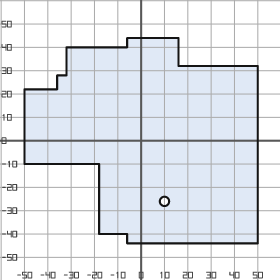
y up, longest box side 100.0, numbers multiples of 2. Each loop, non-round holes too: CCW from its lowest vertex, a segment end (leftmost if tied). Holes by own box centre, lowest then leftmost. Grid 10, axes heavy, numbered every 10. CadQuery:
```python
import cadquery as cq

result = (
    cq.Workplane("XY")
    .moveTo(-6.0, -44.0)
    .lineTo(50.0, -44.0)
    .lineTo(50.0, 32.0)
    .lineTo(16.0, 32.0)
    .lineTo(16.0, 44.0)
    .lineTo(-6.0, 44.0)
    .lineTo(-6.0, 40.0)
    .lineTo(-32.0, 40.0)
    .lineTo(-32.0, 28.0)
    .lineTo(-36.0, 28.0)
    .lineTo(-36.0, 22.0)
    .lineTo(-50.0, 22.0)
    .lineTo(-50.0, -10.0)
    .lineTo(-18.0, -10.0)
    .lineTo(-18.0, -40.0)
    .lineTo(-6.0, -40.0)
    .close()
    .moveTo(10.0, -26.0)
    .circle(2.0)
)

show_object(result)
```